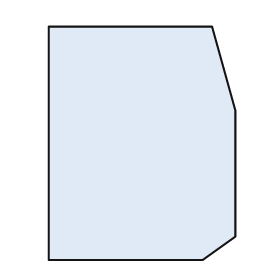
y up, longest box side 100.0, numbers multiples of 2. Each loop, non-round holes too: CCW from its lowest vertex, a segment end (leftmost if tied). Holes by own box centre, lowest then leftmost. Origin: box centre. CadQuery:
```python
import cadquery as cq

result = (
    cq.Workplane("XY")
    .moveTo(-40.0, -50.0)
    .lineTo(26.0, -50.0)
    .lineTo(40.0, -40.0)
    .lineTo(40.0, 14.0)
    .lineTo(30.0, 50.0)
    .lineTo(-40.0, 50.0)
    .close()
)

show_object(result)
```